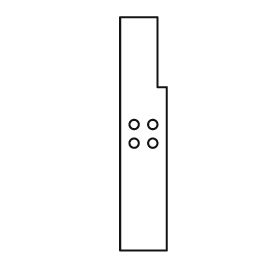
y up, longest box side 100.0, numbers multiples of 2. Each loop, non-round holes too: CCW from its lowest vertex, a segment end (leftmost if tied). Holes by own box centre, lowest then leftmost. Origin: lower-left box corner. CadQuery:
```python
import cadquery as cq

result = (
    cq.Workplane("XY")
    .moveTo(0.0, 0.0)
    .lineTo(20.0, 0.0)
    .lineTo(20.0, 70.0)
    .lineTo(16.0, 70.0)
    .lineTo(16.0, 100.0)
    .lineTo(0.0, 100.0)
    .close()
    .moveTo(6.0, 46.0)
    .circle(2.0)
    .moveTo(14.0, 46.0)
    .circle(2.0)
    .moveTo(6.0, 54.0)
    .circle(2.0)
    .moveTo(14.0, 54.0)
    .circle(2.0)
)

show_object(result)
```